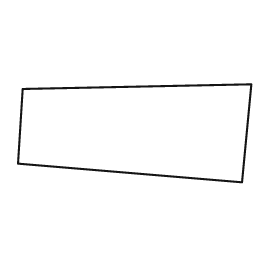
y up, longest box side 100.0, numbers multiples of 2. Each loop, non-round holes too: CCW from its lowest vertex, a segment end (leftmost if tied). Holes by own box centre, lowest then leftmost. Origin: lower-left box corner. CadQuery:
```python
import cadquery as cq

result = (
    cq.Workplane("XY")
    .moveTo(96.0, 0.0)
    .lineTo(100.0, 42.0)
    .lineTo(2.0, 40.0)
    .lineTo(0.0, 8.0)
    .close()
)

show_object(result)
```